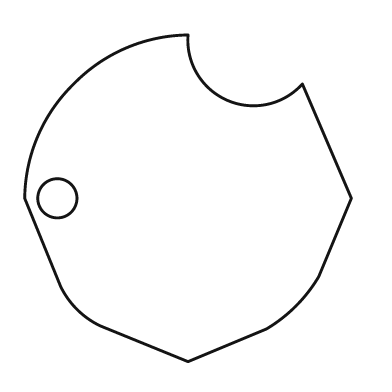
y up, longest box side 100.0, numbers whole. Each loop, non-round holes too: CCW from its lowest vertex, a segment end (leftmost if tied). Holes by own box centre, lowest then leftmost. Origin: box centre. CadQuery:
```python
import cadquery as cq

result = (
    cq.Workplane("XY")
    .moveTo(0.0, -50.0)
    .lineTo(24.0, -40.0)
    .threePointArc((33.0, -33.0), (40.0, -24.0))
    .lineTo(50.0, 0.0)
    .lineTo(35.0, 35.0)
    .threePointArc((12.0, 30.0), (0.0, 50.0))
    .threePointArc((-19.0, 46.0), (-35.0, 35.0))
    .threePointArc((-46.0, 19.0), (-50.0, 0.0))
    .lineTo(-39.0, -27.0)
    .threePointArc((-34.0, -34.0), (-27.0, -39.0))
    .close()
    .moveTo(-40.0, 0.0)
    .circle(6.0)
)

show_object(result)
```